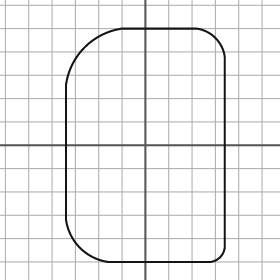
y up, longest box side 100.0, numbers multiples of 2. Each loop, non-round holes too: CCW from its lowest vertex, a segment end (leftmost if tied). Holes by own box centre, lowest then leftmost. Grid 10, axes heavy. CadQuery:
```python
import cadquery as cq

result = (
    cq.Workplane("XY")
    .moveTo(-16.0, -50.0)
    .lineTo(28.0, -50.0)
    .threePointArc((32.0, -48.0), (34.0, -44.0))
    .lineTo(34.0, 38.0)
    .threePointArc((30.0, 46.0), (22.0, 50.0))
    .lineTo(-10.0, 50.0)
    .threePointArc((-26.0, 42.0), (-34.0, 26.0))
    .lineTo(-34.0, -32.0)
    .threePointArc((-28.0, -44.0), (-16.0, -50.0))
    .close()
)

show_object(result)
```